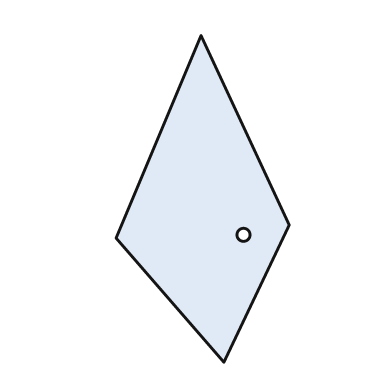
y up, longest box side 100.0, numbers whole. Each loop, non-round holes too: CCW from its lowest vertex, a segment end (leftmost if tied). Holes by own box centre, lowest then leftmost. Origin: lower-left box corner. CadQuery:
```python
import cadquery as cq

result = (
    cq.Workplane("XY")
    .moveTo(33.0, 0.0)
    .lineTo(53.0, 42.0)
    .lineTo(26.0, 100.0)
    .lineTo(0.0, 38.0)
    .close()
    .moveTo(39.0, 39.0)
    .circle(2.0)
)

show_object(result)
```